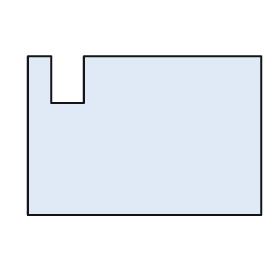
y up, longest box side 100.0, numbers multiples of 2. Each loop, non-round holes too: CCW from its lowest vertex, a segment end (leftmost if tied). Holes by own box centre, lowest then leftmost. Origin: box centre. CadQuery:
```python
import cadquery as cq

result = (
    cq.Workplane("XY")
    .moveTo(-50.0, -34.0)
    .lineTo(50.0, -34.0)
    .lineTo(50.0, 34.0)
    .lineTo(-26.0, 34.0)
    .lineTo(-26.0, 14.0)
    .lineTo(-40.0, 14.0)
    .lineTo(-40.0, 34.0)
    .lineTo(-50.0, 34.0)
    .close()
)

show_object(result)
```